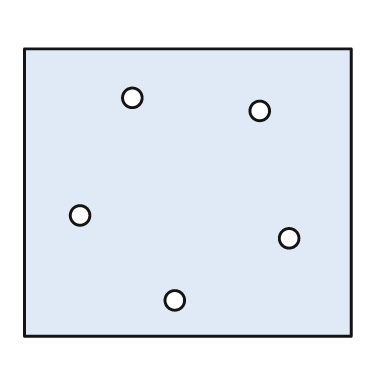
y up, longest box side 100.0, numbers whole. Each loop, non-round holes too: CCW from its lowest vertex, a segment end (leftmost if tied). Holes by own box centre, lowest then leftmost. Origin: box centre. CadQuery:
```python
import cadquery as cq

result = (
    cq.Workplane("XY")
    .moveTo(-50.0, -44.0)
    .lineTo(50.0, -44.0)
    .lineTo(50.0, 44.0)
    .lineTo(-50.0, 44.0)
    .close()
    .moveTo(-4.0, -33.0)
    .circle(3.0)
    .moveTo(31.0, -14.0)
    .circle(3.0)
    .moveTo(-33.0, -7.0)
    .circle(3.0)
    .moveTo(22.0, 25.0)
    .circle(3.0)
    .moveTo(-17.0, 29.0)
    .circle(3.0)
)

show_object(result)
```